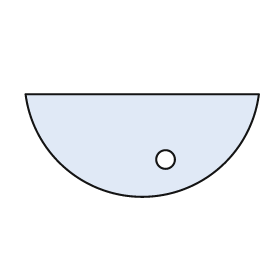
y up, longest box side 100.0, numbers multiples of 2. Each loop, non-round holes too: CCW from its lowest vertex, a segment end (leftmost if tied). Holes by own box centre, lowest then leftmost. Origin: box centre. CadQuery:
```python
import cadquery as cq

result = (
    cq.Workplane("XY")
    .moveTo(-50.0, 22.0)
    .threePointArc((0.0, -22.0), (50.0, 22.0))
    .close()
    .moveTo(10.0, -6.0)
    .circle(4.0)
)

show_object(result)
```